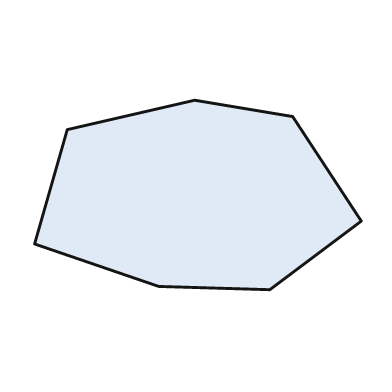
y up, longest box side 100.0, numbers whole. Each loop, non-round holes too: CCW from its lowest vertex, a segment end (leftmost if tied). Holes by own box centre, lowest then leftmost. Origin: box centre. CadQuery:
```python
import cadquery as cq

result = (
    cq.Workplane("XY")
    .moveTo(22.0, -29.0)
    .lineTo(50.0, -8.0)
    .lineTo(29.0, 24.0)
    .lineTo(-1.0, 29.0)
    .lineTo(-40.0, 20.0)
    .lineTo(-50.0, -15.0)
    .lineTo(-12.0, -28.0)
    .close()
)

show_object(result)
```